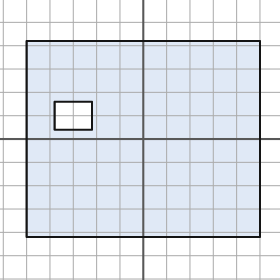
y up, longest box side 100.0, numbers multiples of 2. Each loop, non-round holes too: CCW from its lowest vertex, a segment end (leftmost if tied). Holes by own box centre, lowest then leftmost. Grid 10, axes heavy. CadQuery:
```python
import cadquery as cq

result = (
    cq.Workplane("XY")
    .moveTo(-50.0, -42.0)
    .lineTo(50.0, -42.0)
    .lineTo(50.0, 42.0)
    .lineTo(-50.0, 42.0)
    .close()
    .moveTo(-38.0, 4.0)
    .lineTo(-22.0, 4.0)
    .lineTo(-22.0, 16.0)
    .lineTo(-38.0, 16.0)
    .close()
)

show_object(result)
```